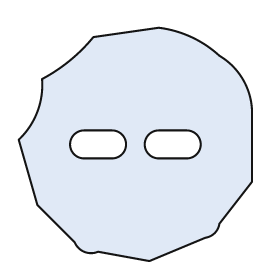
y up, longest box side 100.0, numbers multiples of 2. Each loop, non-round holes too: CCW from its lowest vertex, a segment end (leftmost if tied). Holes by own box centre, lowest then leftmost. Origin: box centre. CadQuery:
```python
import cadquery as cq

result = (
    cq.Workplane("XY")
    .moveTo(6.0, -50.0)
    .lineTo(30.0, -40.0)
    .threePointArc((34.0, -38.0), (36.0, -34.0))
    .lineTo(50.0, -16.0)
    .lineTo(50.0, 14.0)
    .threePointArc((46.0, 28.0), (36.0, 38.0))
    .threePointArc((24.0, 46.0), (10.0, 50.0))
    .lineTo(-18.0, 46.0)
    .threePointArc((-28.0, 36.0), (-40.0, 28.0))
    .threePointArc((-42.0, 14.0), (-50.0, 2.0))
    .lineTo(-42.0, -26.0)
    .lineTo(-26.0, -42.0)
    .threePointArc((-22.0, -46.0), (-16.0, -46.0))
    .close()
    .moveTo(-22.0, -6.0)
    .lineTo(-10.0, -6.0)
    .threePointArc((-4.0, 0.0), (-10.0, 6.0))
    .lineTo(-22.0, 6.0)
    .threePointArc((-28.0, 0.0), (-22.0, -6.0))
    .close()
    .moveTo(10.0, -6.0)
    .lineTo(22.0, -6.0)
    .threePointArc((28.0, 0.0), (22.0, 6.0))
    .lineTo(10.0, 6.0)
    .threePointArc((4.0, 0.0), (10.0, -6.0))
    .close()
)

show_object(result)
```